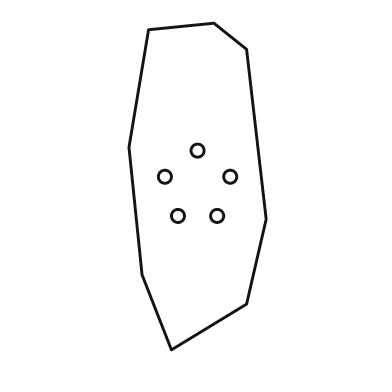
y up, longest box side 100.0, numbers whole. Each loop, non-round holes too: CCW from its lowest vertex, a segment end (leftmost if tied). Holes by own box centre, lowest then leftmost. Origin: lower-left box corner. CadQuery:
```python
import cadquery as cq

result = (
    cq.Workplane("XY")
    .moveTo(13.0, 0.0)
    .lineTo(36.0, 14.0)
    .lineTo(42.0, 40.0)
    .lineTo(36.0, 92.0)
    .lineTo(26.0, 100.0)
    .lineTo(6.0, 98.0)
    .lineTo(0.0, 62.0)
    .lineTo(4.0, 23.0)
    .close()
    .moveTo(15.0, 41.0)
    .circle(2.0)
    .moveTo(27.0, 41.0)
    .circle(2.0)
    .moveTo(11.0, 53.0)
    .circle(2.0)
    .moveTo(31.0, 53.0)
    .circle(2.0)
    .moveTo(21.0, 61.0)
    .circle(2.0)
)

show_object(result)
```